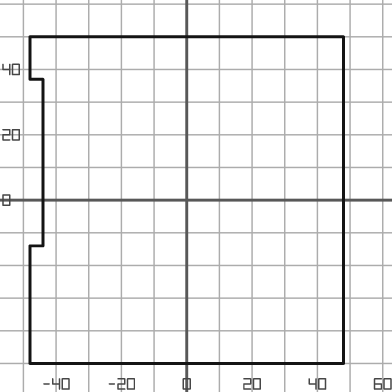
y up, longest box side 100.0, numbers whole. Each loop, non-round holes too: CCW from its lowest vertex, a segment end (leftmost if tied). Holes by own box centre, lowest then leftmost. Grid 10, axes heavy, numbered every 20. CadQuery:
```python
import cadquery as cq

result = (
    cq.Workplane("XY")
    .moveTo(-48.0, -50.0)
    .lineTo(48.0, -50.0)
    .lineTo(48.0, 50.0)
    .lineTo(-48.0, 50.0)
    .lineTo(-48.0, 37.0)
    .lineTo(-44.0, 37.0)
    .lineTo(-44.0, -14.0)
    .lineTo(-48.0, -14.0)
    .close()
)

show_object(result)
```